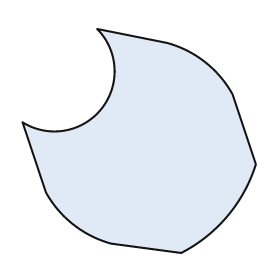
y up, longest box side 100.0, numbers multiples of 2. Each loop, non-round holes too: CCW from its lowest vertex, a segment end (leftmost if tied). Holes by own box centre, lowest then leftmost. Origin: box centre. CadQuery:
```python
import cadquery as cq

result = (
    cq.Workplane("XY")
    .moveTo(18.0, -48.0)
    .threePointArc((38.0, -32.0), (50.0, -10.0))
    .lineTo(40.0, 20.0)
    .threePointArc((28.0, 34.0), (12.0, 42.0))
    .lineTo(-18.0, 48.0)
    .threePointArc((-16.0, 14.0), (-50.0, 8.0))
    .lineTo(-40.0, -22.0)
    .threePointArc((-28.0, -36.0), (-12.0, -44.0))
    .close()
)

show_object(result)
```